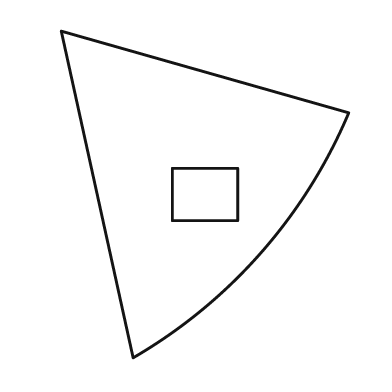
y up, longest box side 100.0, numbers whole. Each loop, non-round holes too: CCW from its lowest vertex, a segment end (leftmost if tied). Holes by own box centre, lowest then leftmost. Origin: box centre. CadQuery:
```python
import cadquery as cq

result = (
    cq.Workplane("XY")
    .moveTo(-22.0, -50.0)
    .threePointArc((17.0, -18.0), (44.0, 25.0))
    .lineTo(-44.0, 50.0)
    .close()
    .moveTo(-10.0, -8.0)
    .lineTo(10.0, -8.0)
    .lineTo(10.0, 8.0)
    .lineTo(-10.0, 8.0)
    .close()
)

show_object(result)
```